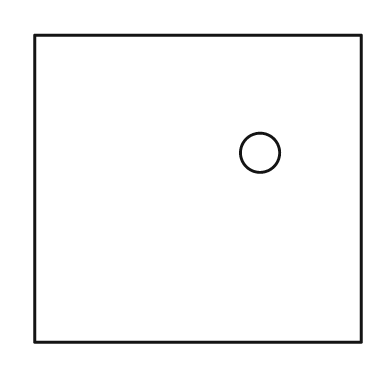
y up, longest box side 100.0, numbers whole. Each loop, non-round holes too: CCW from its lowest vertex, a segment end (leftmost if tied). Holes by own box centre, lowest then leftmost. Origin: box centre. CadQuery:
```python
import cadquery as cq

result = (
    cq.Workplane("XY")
    .moveTo(-50.0, -47.0)
    .lineTo(50.0, -47.0)
    .lineTo(50.0, 47.0)
    .lineTo(-50.0, 47.0)
    .close()
    .moveTo(19.0, 11.0)
    .circle(6.0)
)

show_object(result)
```